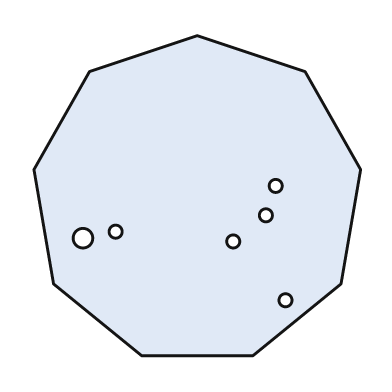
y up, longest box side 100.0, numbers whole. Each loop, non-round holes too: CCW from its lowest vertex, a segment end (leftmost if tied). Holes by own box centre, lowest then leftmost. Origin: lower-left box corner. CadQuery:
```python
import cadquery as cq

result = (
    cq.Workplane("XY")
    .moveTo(33.0, 0.0)
    .lineTo(67.0, 0.0)
    .lineTo(94.0, 22.0)
    .lineTo(100.0, 57.0)
    .lineTo(83.0, 87.0)
    .lineTo(50.0, 98.0)
    .lineTo(17.0, 87.0)
    .lineTo(0.0, 57.0)
    .lineTo(6.0, 22.0)
    .close()
    .moveTo(77.0, 17.0)
    .circle(2.0)
    .moveTo(61.0, 35.0)
    .circle(2.0)
    .moveTo(15.0, 36.0)
    .circle(3.0)
    .moveTo(25.0, 38.0)
    .circle(2.0)
    .moveTo(71.0, 43.0)
    .circle(2.0)
    .moveTo(74.0, 52.0)
    .circle(2.0)
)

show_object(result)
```